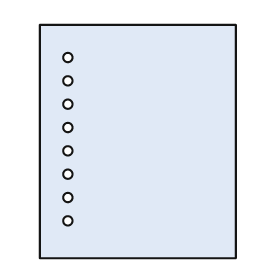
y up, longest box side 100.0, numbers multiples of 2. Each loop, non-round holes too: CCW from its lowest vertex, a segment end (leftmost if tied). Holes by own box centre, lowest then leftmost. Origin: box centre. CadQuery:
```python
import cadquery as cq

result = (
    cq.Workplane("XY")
    .moveTo(-42.0, -50.0)
    .lineTo(42.0, -50.0)
    .lineTo(42.0, 50.0)
    .lineTo(-42.0, 50.0)
    .close()
    .moveTo(-30.0, -34.0)
    .circle(2.0)
    .moveTo(-30.0, -24.0)
    .circle(2.0)
    .moveTo(-30.0, -14.0)
    .circle(2.0)
    .moveTo(-30.0, -4.0)
    .circle(2.0)
    .moveTo(-30.0, 6.0)
    .circle(2.0)
    .moveTo(-30.0, 16.0)
    .circle(2.0)
    .moveTo(-30.0, 26.0)
    .circle(2.0)
    .moveTo(-30.0, 36.0)
    .circle(2.0)
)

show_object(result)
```